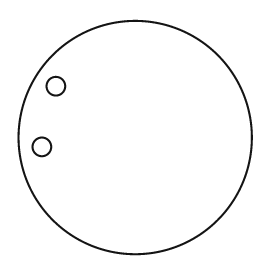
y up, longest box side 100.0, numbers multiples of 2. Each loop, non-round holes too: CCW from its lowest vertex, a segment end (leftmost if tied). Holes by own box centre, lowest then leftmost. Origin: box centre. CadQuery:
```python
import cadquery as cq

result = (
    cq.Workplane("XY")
    .moveTo(0.0, 0.0)
    .circle(50.0)
    .moveTo(-40.0, -4.0)
    .circle(4.0)
    .moveTo(-34.0, 22.0)
    .circle(4.0)
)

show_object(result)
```